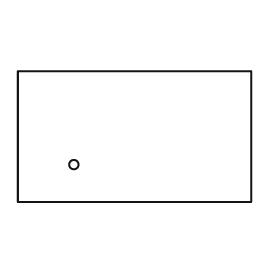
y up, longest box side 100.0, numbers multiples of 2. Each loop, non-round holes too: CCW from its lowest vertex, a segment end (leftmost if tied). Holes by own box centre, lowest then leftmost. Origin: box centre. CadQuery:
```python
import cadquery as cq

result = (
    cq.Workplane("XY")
    .moveTo(-50.0, -28.0)
    .lineTo(50.0, -28.0)
    .lineTo(50.0, 28.0)
    .lineTo(-50.0, 28.0)
    .close()
    .moveTo(-26.0, -12.0)
    .circle(2.0)
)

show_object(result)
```